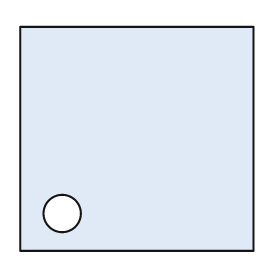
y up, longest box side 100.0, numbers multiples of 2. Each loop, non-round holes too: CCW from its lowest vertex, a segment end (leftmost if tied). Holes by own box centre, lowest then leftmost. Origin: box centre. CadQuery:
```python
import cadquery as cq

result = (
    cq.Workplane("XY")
    .moveTo(-50.0, -48.0)
    .lineTo(50.0, -48.0)
    .lineTo(50.0, 48.0)
    .lineTo(-50.0, 48.0)
    .close()
    .moveTo(-32.0, -32.0)
    .circle(8.0)
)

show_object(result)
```